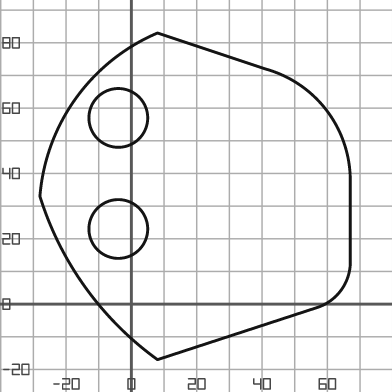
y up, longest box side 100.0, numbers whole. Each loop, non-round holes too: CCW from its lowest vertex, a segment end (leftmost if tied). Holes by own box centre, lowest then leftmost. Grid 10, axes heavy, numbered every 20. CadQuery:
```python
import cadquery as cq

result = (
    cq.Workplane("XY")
    .moveTo(8.0, -17.0)
    .lineTo(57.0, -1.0)
    .threePointArc((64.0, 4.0), (67.0, 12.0))
    .lineTo(67.0, 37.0)
    .threePointArc((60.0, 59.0), (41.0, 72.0))
    .lineTo(8.0, 83.0)
    .threePointArc((-17.0, 63.0), (-28.0, 33.0))
    .threePointArc((-14.0, 5.0), (8.0, -17.0))
    .close()
    .moveTo(-4.0, 23.0)
    .circle(9.0)
    .moveTo(-4.0, 57.0)
    .circle(9.0)
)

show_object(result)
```